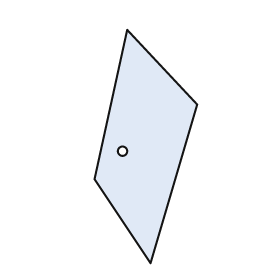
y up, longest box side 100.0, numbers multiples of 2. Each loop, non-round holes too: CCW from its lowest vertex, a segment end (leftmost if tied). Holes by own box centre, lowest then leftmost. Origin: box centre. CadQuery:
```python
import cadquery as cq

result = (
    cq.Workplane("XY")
    .moveTo(2.0, -50.0)
    .lineTo(22.0, 18.0)
    .lineTo(-8.0, 50.0)
    .lineTo(-22.0, -14.0)
    .close()
    .moveTo(-10.0, -2.0)
    .circle(2.0)
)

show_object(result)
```